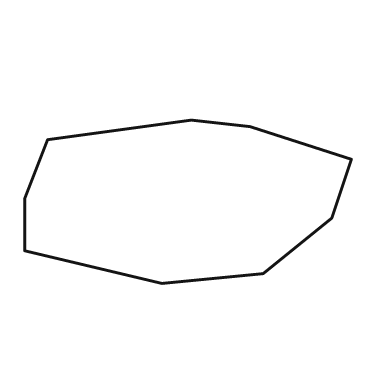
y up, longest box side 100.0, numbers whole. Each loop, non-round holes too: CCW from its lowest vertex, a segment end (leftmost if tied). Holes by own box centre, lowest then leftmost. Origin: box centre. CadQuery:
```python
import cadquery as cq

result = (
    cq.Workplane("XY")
    .moveTo(-8.0, -25.0)
    .lineTo(23.0, -22.0)
    .lineTo(44.0, -5.0)
    .lineTo(50.0, 13.0)
    .lineTo(19.0, 23.0)
    .lineTo(1.0, 25.0)
    .lineTo(-43.0, 19.0)
    .lineTo(-50.0, 1.0)
    .lineTo(-50.0, -15.0)
    .close()
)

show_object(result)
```